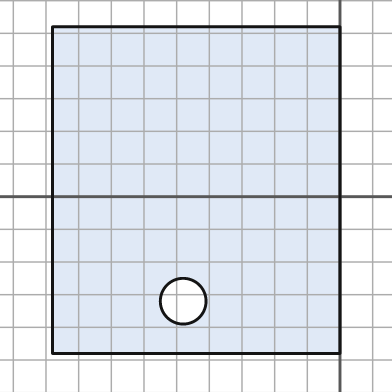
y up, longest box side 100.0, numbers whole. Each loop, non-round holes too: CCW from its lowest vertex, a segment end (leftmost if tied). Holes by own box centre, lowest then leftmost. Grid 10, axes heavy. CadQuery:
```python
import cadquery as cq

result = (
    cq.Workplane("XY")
    .moveTo(-88.0, -48.0)
    .lineTo(0.0, -48.0)
    .lineTo(0.0, 52.0)
    .lineTo(-88.0, 52.0)
    .close()
    .moveTo(-48.0, -32.0)
    .circle(7.0)
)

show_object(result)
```